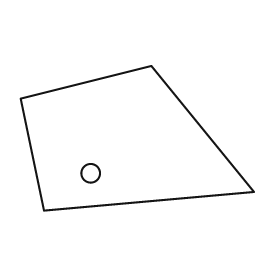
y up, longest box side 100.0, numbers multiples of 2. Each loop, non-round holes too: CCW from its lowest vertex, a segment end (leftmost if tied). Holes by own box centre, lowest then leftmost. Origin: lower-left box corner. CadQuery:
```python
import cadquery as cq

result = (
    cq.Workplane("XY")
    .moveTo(10.0, 0.0)
    .lineTo(100.0, 8.0)
    .lineTo(56.0, 62.0)
    .lineTo(0.0, 48.0)
    .close()
    .moveTo(30.0, 16.0)
    .circle(4.0)
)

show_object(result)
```